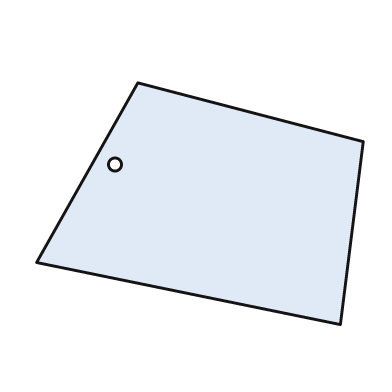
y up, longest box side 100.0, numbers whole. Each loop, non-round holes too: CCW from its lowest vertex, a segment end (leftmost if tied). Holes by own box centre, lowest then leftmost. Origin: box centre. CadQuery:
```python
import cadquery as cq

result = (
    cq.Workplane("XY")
    .moveTo(43.0, -37.0)
    .lineTo(50.0, 19.0)
    .lineTo(-19.0, 37.0)
    .lineTo(-50.0, -18.0)
    .close()
    .moveTo(-26.0, 12.0)
    .circle(2.0)
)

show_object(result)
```